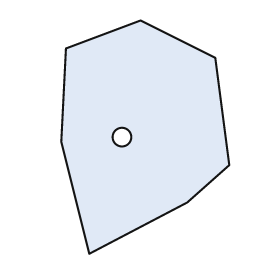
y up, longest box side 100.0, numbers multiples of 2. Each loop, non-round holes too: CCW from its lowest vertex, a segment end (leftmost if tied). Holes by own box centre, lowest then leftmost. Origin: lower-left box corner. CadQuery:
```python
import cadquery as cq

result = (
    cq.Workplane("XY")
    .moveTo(12.0, 0.0)
    .lineTo(54.0, 22.0)
    .lineTo(72.0, 38.0)
    .lineTo(66.0, 84.0)
    .lineTo(34.0, 100.0)
    .lineTo(2.0, 88.0)
    .lineTo(0.0, 48.0)
    .close()
    .moveTo(26.0, 50.0)
    .circle(4.0)
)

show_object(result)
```